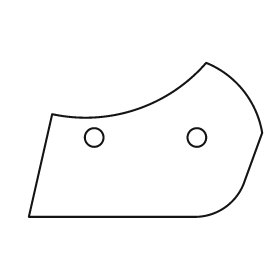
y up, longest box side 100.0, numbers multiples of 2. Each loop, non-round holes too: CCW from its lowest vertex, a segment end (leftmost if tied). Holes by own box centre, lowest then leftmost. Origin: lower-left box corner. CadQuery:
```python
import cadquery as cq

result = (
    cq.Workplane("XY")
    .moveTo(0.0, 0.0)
    .lineTo(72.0, 0.0)
    .threePointArc((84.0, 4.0), (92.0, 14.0))
    .lineTo(100.0, 36.0)
    .threePointArc((92.0, 54.0), (76.0, 66.0))
    .threePointArc((46.0, 46.0), (10.0, 44.0))
    .close()
    .moveTo(28.0, 34.0)
    .circle(4.0)
    .moveTo(72.0, 34.0)
    .circle(4.0)
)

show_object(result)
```